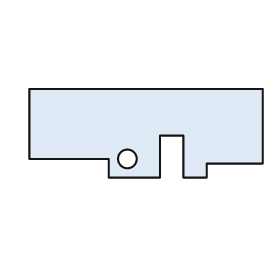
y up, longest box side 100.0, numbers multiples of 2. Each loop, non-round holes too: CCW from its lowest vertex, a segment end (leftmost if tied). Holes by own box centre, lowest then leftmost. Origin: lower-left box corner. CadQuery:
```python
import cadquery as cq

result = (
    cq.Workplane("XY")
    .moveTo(34.0, 0.0)
    .lineTo(56.0, 0.0)
    .lineTo(56.0, 18.0)
    .lineTo(66.0, 18.0)
    .lineTo(66.0, 0.0)
    .lineTo(76.0, 0.0)
    .lineTo(76.0, 6.0)
    .lineTo(100.0, 6.0)
    .lineTo(100.0, 38.0)
    .lineTo(0.0, 38.0)
    .lineTo(0.0, 8.0)
    .lineTo(34.0, 8.0)
    .close()
    .moveTo(42.0, 8.0)
    .circle(4.0)
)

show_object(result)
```